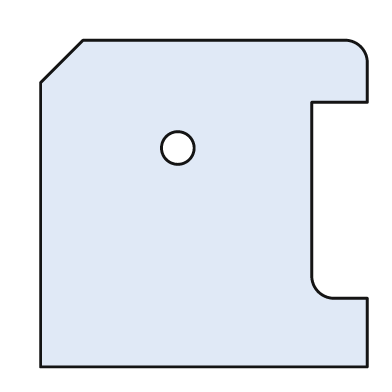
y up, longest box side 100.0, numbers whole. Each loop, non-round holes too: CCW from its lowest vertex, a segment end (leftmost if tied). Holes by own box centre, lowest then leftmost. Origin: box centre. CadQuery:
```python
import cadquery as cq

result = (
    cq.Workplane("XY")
    .moveTo(-50.0, -50.0)
    .lineTo(50.0, -50.0)
    .lineTo(50.0, -29.0)
    .lineTo(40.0, -29.0)
    .threePointArc((35.0, -27.0), (33.0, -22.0))
    .lineTo(33.0, 31.0)
    .lineTo(50.0, 31.0)
    .lineTo(50.0, 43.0)
    .threePointArc((48.0, 48.0), (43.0, 50.0))
    .lineTo(-37.0, 50.0)
    .lineTo(-50.0, 37.0)
    .close()
    .moveTo(-8.0, 17.0)
    .circle(5.0)
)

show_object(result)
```